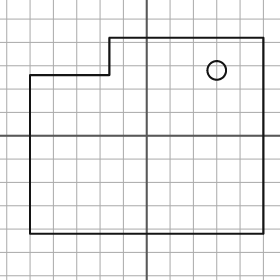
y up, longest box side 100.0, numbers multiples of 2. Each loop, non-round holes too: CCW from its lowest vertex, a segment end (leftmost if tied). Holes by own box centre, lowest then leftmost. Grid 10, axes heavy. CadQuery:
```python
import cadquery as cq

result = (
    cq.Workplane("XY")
    .moveTo(-50.0, -42.0)
    .lineTo(50.0, -42.0)
    .lineTo(50.0, 42.0)
    .lineTo(-16.0, 42.0)
    .lineTo(-16.0, 26.0)
    .lineTo(-50.0, 26.0)
    .close()
    .moveTo(30.0, 28.0)
    .circle(4.0)
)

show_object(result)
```